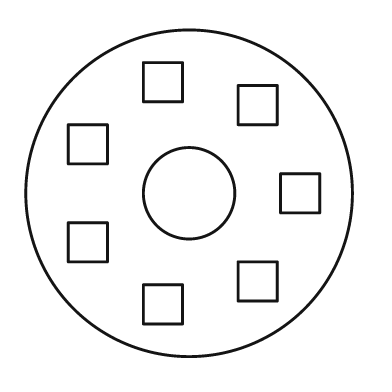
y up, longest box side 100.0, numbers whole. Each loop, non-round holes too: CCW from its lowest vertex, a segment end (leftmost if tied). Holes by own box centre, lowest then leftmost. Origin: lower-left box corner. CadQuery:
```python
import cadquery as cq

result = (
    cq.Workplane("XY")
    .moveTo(50.0, 50.0)
    .circle(50.0)
    .moveTo(36.0, 10.0)
    .lineTo(48.0, 10.0)
    .lineTo(48.0, 22.0)
    .lineTo(36.0, 22.0)
    .close()
    .moveTo(65.0, 17.0)
    .lineTo(77.0, 17.0)
    .lineTo(77.0, 29.0)
    .lineTo(65.0, 29.0)
    .close()
    .moveTo(13.0, 29.0)
    .lineTo(25.0, 29.0)
    .lineTo(25.0, 41.0)
    .lineTo(13.0, 41.0)
    .close()
    .moveTo(50.0, 50.0)
    .circle(14.0)
    .moveTo(78.0, 44.0)
    .lineTo(90.0, 44.0)
    .lineTo(90.0, 56.0)
    .lineTo(78.0, 56.0)
    .close()
    .moveTo(13.0, 59.0)
    .lineTo(25.0, 59.0)
    .lineTo(25.0, 71.0)
    .lineTo(13.0, 71.0)
    .close()
    .moveTo(65.0, 71.0)
    .lineTo(77.0, 71.0)
    .lineTo(77.0, 83.0)
    .lineTo(65.0, 83.0)
    .close()
    .moveTo(36.0, 78.0)
    .lineTo(48.0, 78.0)
    .lineTo(48.0, 90.0)
    .lineTo(36.0, 90.0)
    .close()
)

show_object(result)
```